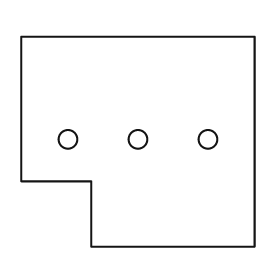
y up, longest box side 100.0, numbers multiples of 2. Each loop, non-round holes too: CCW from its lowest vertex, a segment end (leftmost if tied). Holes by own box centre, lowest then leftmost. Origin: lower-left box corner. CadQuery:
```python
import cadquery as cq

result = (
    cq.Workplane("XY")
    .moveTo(30.0, 0.0)
    .lineTo(100.0, 0.0)
    .lineTo(100.0, 90.0)
    .lineTo(0.0, 90.0)
    .lineTo(0.0, 28.0)
    .lineTo(30.0, 28.0)
    .close()
    .moveTo(20.0, 46.0)
    .circle(4.0)
    .moveTo(50.0, 46.0)
    .circle(4.0)
    .moveTo(80.0, 46.0)
    .circle(4.0)
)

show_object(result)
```